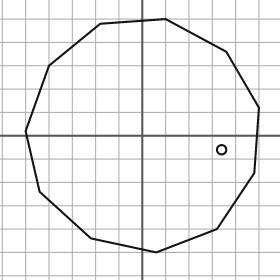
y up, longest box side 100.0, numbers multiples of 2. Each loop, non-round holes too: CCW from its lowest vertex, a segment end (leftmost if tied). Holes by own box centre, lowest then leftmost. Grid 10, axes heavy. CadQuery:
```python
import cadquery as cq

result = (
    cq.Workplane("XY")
    .moveTo(6.0, -50.0)
    .lineTo(32.0, -40.0)
    .lineTo(48.0, -16.0)
    .lineTo(50.0, 12.0)
    .lineTo(36.0, 36.0)
    .lineTo(10.0, 50.0)
    .lineTo(-18.0, 48.0)
    .lineTo(-40.0, 30.0)
    .lineTo(-50.0, 2.0)
    .lineTo(-44.0, -24.0)
    .lineTo(-22.0, -44.0)
    .close()
    .moveTo(34.0, -6.0)
    .circle(2.0)
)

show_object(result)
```